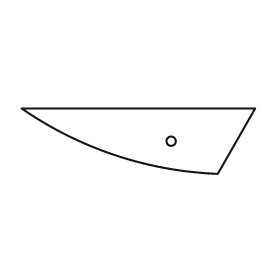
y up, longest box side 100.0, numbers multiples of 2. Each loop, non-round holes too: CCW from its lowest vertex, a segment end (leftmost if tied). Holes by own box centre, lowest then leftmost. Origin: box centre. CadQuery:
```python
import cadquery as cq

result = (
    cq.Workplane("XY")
    .moveTo(34.0, -14.0)
    .lineTo(50.0, 14.0)
    .lineTo(-50.0, 14.0)
    .threePointArc((-10.0, -6.0), (34.0, -14.0))
    .close()
    .moveTo(14.0, 0.0)
    .circle(2.0)
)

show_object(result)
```